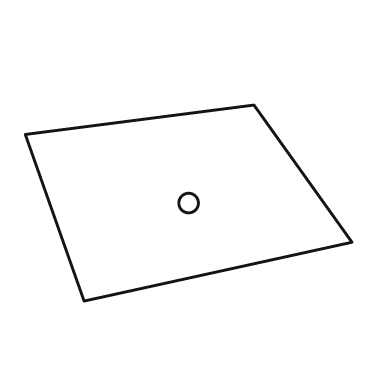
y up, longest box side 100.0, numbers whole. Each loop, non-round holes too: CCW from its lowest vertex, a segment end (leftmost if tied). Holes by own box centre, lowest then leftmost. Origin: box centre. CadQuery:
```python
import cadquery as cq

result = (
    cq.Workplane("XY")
    .moveTo(-32.0, -30.0)
    .lineTo(50.0, -12.0)
    .lineTo(20.0, 30.0)
    .lineTo(-50.0, 21.0)
    .close()
    .moveTo(0.0, 0.0)
    .circle(3.0)
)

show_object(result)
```